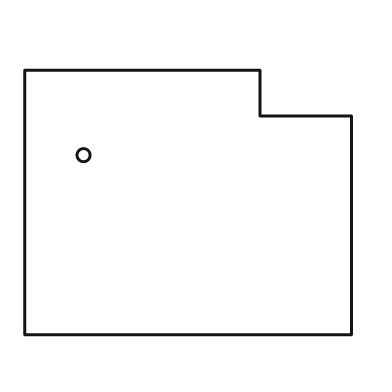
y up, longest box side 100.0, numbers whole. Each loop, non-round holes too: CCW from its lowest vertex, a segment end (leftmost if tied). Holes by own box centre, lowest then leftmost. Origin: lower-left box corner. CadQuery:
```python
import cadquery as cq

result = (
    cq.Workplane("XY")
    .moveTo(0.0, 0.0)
    .lineTo(100.0, 0.0)
    .lineTo(100.0, 67.0)
    .lineTo(72.0, 67.0)
    .lineTo(72.0, 81.0)
    .lineTo(0.0, 81.0)
    .close()
    .moveTo(18.0, 55.0)
    .circle(2.0)
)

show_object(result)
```